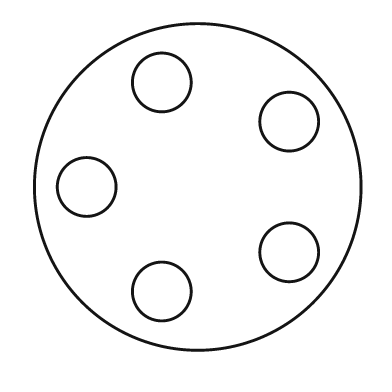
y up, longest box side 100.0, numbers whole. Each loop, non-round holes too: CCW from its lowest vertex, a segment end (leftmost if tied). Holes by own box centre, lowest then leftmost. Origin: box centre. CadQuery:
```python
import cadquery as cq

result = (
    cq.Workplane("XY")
    .moveTo(0.0, 0.0)
    .circle(50.0)
    .moveTo(-11.0, -32.0)
    .circle(9.0)
    .moveTo(28.0, -20.0)
    .circle(9.0)
    .moveTo(-34.0, 0.0)
    .circle(9.0)
    .moveTo(28.0, 20.0)
    .circle(9.0)
    .moveTo(-11.0, 32.0)
    .circle(9.0)
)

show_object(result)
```